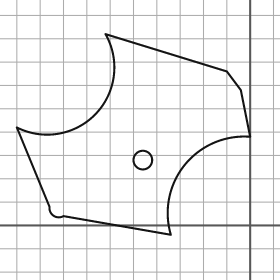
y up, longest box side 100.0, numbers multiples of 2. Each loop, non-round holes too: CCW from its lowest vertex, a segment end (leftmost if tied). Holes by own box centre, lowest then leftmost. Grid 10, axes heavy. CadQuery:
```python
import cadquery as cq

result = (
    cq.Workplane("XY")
    .moveTo(-34.0, -4.0)
    .threePointArc((-28.0, 26.0), (0.0, 38.0))
    .lineTo(-4.0, 58.0)
    .lineTo(-10.0, 66.0)
    .lineTo(-62.0, 82.0)
    .threePointArc((-66.0, 48.0), (-100.0, 42.0))
    .lineTo(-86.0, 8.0)
    .threePointArc((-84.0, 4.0), (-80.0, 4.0))
    .close()
    .moveTo(-46.0, 28.0)
    .circle(4.0)
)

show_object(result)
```